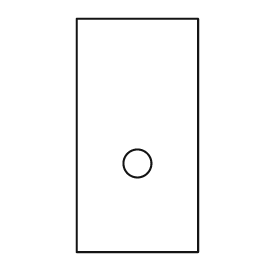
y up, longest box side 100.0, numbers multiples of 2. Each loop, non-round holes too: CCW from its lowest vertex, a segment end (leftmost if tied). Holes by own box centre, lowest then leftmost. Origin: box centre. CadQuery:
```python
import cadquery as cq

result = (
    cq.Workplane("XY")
    .moveTo(-26.0, -50.0)
    .lineTo(26.0, -50.0)
    .lineTo(26.0, 50.0)
    .lineTo(-26.0, 50.0)
    .close()
    .moveTo(0.0, -12.0)
    .circle(6.0)
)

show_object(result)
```